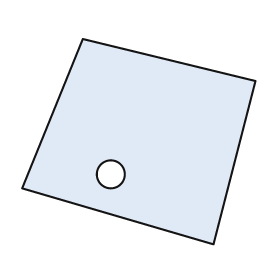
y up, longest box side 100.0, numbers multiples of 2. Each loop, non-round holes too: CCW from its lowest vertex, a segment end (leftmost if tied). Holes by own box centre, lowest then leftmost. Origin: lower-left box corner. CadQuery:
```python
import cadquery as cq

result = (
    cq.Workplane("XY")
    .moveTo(82.0, 0.0)
    .lineTo(100.0, 70.0)
    .lineTo(26.0, 88.0)
    .lineTo(0.0, 24.0)
    .close()
    .moveTo(38.0, 30.0)
    .circle(6.0)
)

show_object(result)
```